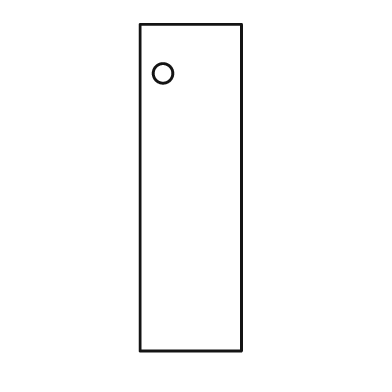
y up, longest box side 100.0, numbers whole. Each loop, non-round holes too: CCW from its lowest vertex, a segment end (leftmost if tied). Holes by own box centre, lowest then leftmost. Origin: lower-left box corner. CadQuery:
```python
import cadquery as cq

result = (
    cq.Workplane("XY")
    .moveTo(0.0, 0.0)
    .lineTo(31.0, 0.0)
    .lineTo(31.0, 100.0)
    .lineTo(0.0, 100.0)
    .close()
    .moveTo(7.0, 85.0)
    .circle(3.0)
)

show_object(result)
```